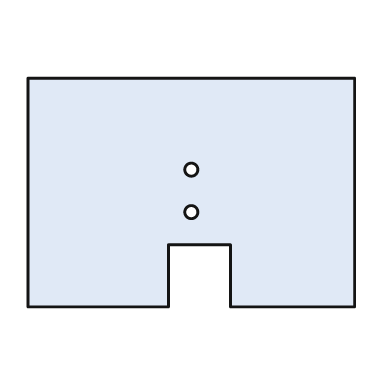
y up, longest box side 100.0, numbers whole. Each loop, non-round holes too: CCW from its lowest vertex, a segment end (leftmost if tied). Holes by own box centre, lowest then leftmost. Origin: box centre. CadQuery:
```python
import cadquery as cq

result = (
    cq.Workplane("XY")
    .moveTo(-50.0, -35.0)
    .lineTo(-7.0, -35.0)
    .lineTo(-7.0, -16.0)
    .lineTo(12.0, -16.0)
    .lineTo(12.0, -35.0)
    .lineTo(50.0, -35.0)
    .lineTo(50.0, 35.0)
    .lineTo(-50.0, 35.0)
    .close()
    .moveTo(0.0, -6.0)
    .circle(2.0)
    .moveTo(0.0, 7.0)
    .circle(2.0)
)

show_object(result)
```